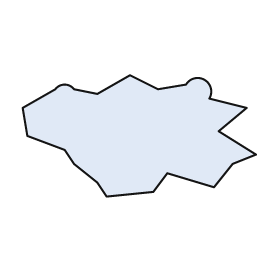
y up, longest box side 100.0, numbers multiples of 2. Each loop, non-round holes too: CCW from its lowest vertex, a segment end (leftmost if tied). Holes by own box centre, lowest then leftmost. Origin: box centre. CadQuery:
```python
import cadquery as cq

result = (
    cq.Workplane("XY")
    .moveTo(-14.0, -26.0)
    .lineTo(6.0, -24.0)
    .lineTo(12.0, -16.0)
    .lineTo(32.0, -22.0)
    .lineTo(40.0, -12.0)
    .lineTo(50.0, -8.0)
    .lineTo(34.0, 2.0)
    .lineTo(46.0, 12.0)
    .lineTo(30.0, 16.0)
    .threePointArc((28.0, 24.0), (20.0, 22.0))
    .lineTo(8.0, 20.0)
    .lineTo(-4.0, 26.0)
    .lineTo(-18.0, 18.0)
    .lineTo(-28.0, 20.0)
    .threePointArc((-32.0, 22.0), (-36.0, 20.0))
    .lineTo(-50.0, 12.0)
    .lineTo(-48.0, 0.0)
    .lineTo(-32.0, -6.0)
    .lineTo(-28.0, -12.0)
    .lineTo(-18.0, -20.0)
    .close()
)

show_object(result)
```